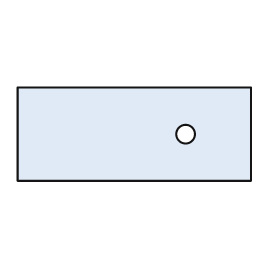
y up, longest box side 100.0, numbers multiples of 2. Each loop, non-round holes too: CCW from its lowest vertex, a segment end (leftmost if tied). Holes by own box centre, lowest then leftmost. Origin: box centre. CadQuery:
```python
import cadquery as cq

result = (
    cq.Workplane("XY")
    .moveTo(-50.0, -20.0)
    .lineTo(50.0, -20.0)
    .lineTo(50.0, 20.0)
    .lineTo(-50.0, 20.0)
    .close()
    .moveTo(22.0, 0.0)
    .circle(4.0)
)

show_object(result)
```